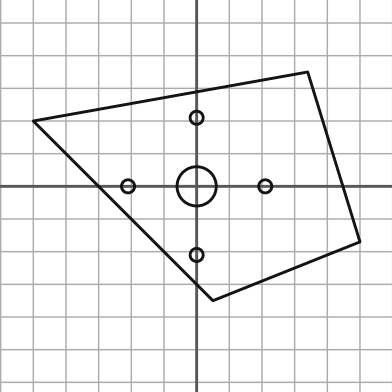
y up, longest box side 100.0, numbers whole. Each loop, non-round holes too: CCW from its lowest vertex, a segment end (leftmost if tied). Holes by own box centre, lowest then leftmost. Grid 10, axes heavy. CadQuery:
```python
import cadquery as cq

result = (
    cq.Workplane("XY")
    .moveTo(5.0, -35.0)
    .lineTo(50.0, -17.0)
    .lineTo(34.0, 35.0)
    .lineTo(-50.0, 20.0)
    .close()
    .moveTo(0.0, -21.0)
    .circle(2.0)
    .moveTo(-21.0, 0.0)
    .circle(2.0)
    .moveTo(0.0, 0.0)
    .circle(6.0)
    .moveTo(21.0, 0.0)
    .circle(2.0)
    .moveTo(0.0, 21.0)
    .circle(2.0)
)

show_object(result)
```